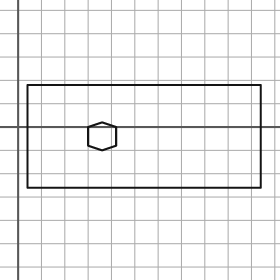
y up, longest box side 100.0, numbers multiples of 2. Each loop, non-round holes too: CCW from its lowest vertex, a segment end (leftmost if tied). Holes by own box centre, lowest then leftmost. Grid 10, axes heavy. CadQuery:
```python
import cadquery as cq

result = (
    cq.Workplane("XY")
    .moveTo(4.0, -26.0)
    .lineTo(104.0, -26.0)
    .lineTo(104.0, 18.0)
    .lineTo(4.0, 18.0)
    .close()
    .moveTo(36.0, -10.0)
    .lineTo(42.0, -8.0)
    .lineTo(42.0, 0.0)
    .lineTo(36.0, 2.0)
    .lineTo(30.0, 0.0)
    .lineTo(30.0, -8.0)
    .close()
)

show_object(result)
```